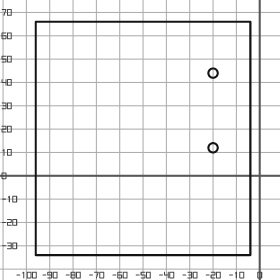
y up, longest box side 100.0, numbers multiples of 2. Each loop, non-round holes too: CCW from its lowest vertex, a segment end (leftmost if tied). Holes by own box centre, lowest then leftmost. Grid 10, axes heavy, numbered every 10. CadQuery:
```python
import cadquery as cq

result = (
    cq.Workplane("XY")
    .moveTo(-96.0, -34.0)
    .lineTo(-4.0, -34.0)
    .lineTo(-4.0, 66.0)
    .lineTo(-96.0, 66.0)
    .close()
    .moveTo(-20.0, 12.0)
    .circle(2.0)
    .moveTo(-20.0, 44.0)
    .circle(2.0)
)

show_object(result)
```